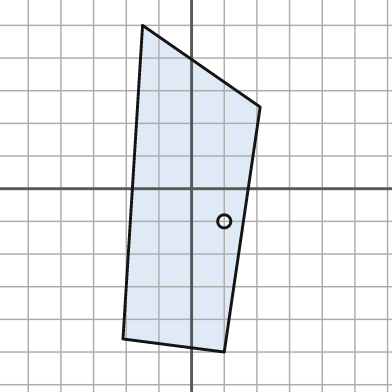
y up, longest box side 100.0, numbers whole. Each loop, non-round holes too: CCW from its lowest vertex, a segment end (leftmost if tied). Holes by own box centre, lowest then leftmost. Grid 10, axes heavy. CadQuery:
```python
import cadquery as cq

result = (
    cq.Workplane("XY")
    .moveTo(10.0, -50.0)
    .lineTo(21.0, 25.0)
    .lineTo(-15.0, 50.0)
    .lineTo(-21.0, -46.0)
    .close()
    .moveTo(10.0, -10.0)
    .circle(2.0)
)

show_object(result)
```